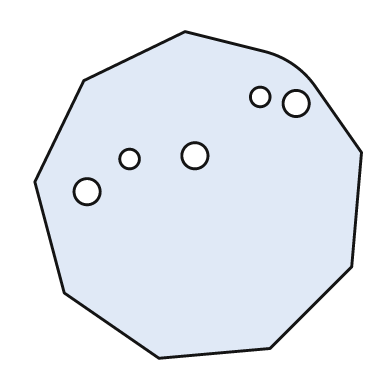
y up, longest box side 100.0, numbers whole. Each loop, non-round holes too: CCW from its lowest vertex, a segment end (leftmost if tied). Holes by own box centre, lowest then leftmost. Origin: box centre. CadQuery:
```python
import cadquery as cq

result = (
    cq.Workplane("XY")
    .moveTo(-12.0, -50.0)
    .lineTo(22.0, -47.0)
    .lineTo(47.0, -22.0)
    .lineTo(50.0, 13.0)
    .lineTo(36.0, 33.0)
    .threePointArc((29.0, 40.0), (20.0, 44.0))
    .lineTo(-4.0, 50.0)
    .lineTo(-35.0, 35.0)
    .lineTo(-50.0, 4.0)
    .lineTo(-41.0, -30.0)
    .close()
    .moveTo(-34.0, 1.0)
    .circle(4.0)
    .moveTo(-21.0, 11.0)
    .circle(3.0)
    .moveTo(-1.0, 12.0)
    .circle(4.0)
    .moveTo(30.0, 28.0)
    .circle(4.0)
    .moveTo(19.0, 30.0)
    .circle(3.0)
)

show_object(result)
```